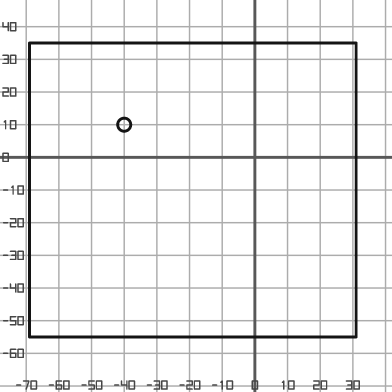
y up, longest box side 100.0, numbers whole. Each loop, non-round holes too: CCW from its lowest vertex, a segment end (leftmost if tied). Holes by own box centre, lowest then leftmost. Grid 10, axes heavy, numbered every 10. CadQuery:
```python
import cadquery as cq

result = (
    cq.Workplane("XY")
    .moveTo(-69.0, -55.0)
    .lineTo(31.0, -55.0)
    .lineTo(31.0, 35.0)
    .lineTo(-69.0, 35.0)
    .close()
    .moveTo(-40.0, 10.0)
    .circle(2.0)
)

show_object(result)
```